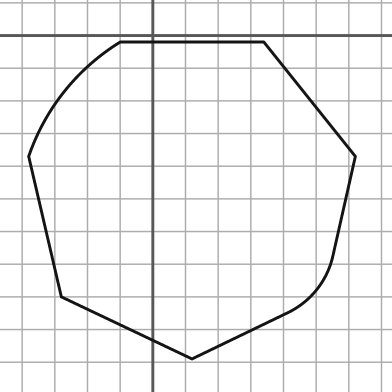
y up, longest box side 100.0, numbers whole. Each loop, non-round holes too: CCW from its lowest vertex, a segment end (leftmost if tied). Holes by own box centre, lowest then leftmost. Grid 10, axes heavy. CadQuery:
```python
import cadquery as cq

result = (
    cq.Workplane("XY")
    .moveTo(12.0, -99.0)
    .lineTo(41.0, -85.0)
    .threePointArc((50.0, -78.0), (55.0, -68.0))
    .lineTo(62.0, -37.0)
    .lineTo(34.0, -2.0)
    .lineTo(-10.0, -2.0)
    .threePointArc((-27.0, -17.0), (-38.0, -37.0))
    .lineTo(-28.0, -80.0)
    .close()
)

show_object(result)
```